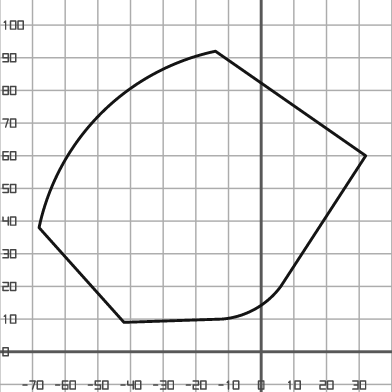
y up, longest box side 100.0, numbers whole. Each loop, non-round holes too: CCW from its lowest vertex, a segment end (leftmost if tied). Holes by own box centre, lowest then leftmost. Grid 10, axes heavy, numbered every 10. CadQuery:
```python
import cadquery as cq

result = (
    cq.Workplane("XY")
    .moveTo(-42.0, 9.0)
    .lineTo(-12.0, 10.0)
    .threePointArc((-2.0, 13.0), (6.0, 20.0))
    .lineTo(32.0, 60.0)
    .lineTo(-14.0, 92.0)
    .threePointArc((-49.0, 73.0), (-68.0, 38.0))
    .close()
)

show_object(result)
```